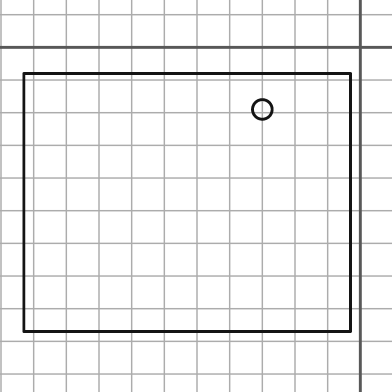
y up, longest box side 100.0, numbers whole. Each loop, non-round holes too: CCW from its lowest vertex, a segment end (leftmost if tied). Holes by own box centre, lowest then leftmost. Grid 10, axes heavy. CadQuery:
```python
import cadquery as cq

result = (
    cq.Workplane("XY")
    .moveTo(-103.0, -87.0)
    .lineTo(-3.0, -87.0)
    .lineTo(-3.0, -8.0)
    .lineTo(-103.0, -8.0)
    .close()
    .moveTo(-30.0, -19.0)
    .circle(3.0)
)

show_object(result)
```